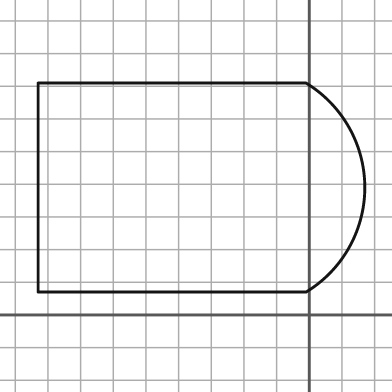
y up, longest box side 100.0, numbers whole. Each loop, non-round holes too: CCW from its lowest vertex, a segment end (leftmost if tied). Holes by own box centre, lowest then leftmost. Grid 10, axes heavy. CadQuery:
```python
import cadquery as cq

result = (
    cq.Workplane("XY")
    .moveTo(-83.0, 7.0)
    .lineTo(-1.0, 7.0)
    .threePointArc((17.0, 39.0), (-1.0, 71.0))
    .lineTo(-83.0, 71.0)
    .close()
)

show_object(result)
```